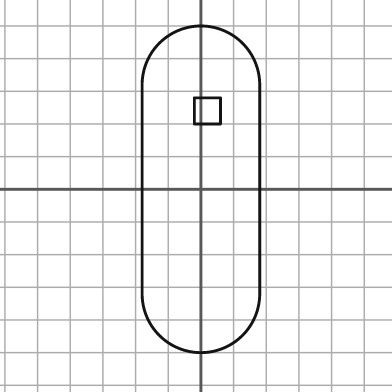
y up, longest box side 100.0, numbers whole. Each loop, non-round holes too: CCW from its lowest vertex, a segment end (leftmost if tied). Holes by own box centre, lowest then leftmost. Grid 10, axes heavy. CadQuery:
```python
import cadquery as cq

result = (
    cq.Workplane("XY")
    .moveTo(-18.0, -32.0)
    .threePointArc((0.0, -50.0), (18.0, -32.0))
    .lineTo(18.0, 32.0)
    .threePointArc((0.0, 50.0), (-18.0, 32.0))
    .close()
    .moveTo(-2.0, 20.0)
    .lineTo(6.0, 20.0)
    .lineTo(6.0, 28.0)
    .lineTo(-2.0, 28.0)
    .close()
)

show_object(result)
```